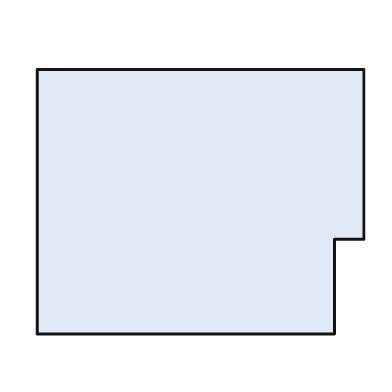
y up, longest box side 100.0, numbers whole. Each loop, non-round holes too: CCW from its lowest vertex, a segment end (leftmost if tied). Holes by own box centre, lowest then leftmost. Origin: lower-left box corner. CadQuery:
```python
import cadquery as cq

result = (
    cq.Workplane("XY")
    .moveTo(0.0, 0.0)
    .lineTo(91.0, 0.0)
    .lineTo(91.0, 29.0)
    .lineTo(100.0, 29.0)
    .lineTo(100.0, 81.0)
    .lineTo(0.0, 81.0)
    .close()
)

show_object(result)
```